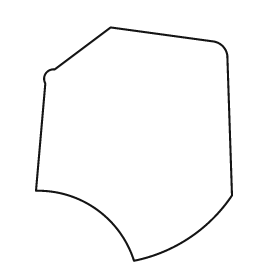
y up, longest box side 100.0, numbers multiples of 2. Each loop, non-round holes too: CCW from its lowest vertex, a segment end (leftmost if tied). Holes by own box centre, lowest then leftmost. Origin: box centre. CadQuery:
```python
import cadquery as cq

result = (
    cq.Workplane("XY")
    .moveTo(0.0, -50.0)
    .threePointArc((24.0, -40.0), (42.0, -22.0))
    .lineTo(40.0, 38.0)
    .threePointArc((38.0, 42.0), (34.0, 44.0))
    .lineTo(-10.0, 50.0)
    .lineTo(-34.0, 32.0)
    .threePointArc((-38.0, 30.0), (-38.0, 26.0))
    .lineTo(-42.0, -20.0)
    .threePointArc((-16.0, -28.0), (0.0, -50.0))
    .close()
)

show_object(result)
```